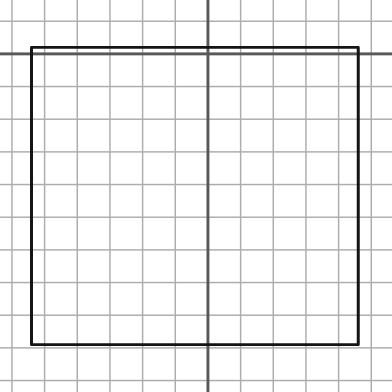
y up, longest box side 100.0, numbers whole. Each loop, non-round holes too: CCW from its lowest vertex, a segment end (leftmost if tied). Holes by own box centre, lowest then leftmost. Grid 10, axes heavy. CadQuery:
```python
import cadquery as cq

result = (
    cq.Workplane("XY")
    .moveTo(-54.0, -89.0)
    .lineTo(46.0, -89.0)
    .lineTo(46.0, 2.0)
    .lineTo(-54.0, 2.0)
    .close()
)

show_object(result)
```